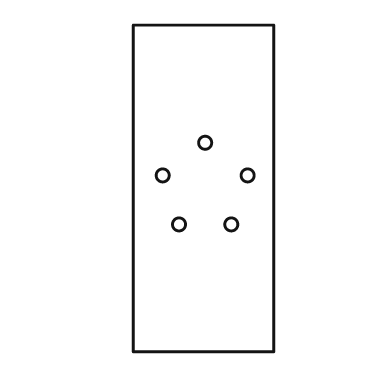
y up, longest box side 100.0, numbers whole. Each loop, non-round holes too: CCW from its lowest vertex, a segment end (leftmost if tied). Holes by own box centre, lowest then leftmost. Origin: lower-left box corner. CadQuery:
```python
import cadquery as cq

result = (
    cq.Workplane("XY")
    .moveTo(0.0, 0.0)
    .lineTo(43.0, 0.0)
    .lineTo(43.0, 100.0)
    .lineTo(0.0, 100.0)
    .close()
    .moveTo(14.0, 39.0)
    .circle(2.0)
    .moveTo(30.0, 39.0)
    .circle(2.0)
    .moveTo(9.0, 54.0)
    .circle(2.0)
    .moveTo(35.0, 54.0)
    .circle(2.0)
    .moveTo(22.0, 64.0)
    .circle(2.0)
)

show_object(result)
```